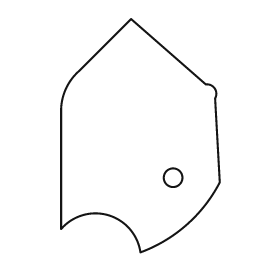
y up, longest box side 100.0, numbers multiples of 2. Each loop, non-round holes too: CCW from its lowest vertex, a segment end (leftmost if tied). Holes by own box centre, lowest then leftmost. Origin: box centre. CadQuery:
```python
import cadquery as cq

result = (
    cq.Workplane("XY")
    .moveTo(0.0, -50.0)
    .threePointArc((20.0, -38.0), (34.0, -20.0))
    .lineTo(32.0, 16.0)
    .threePointArc((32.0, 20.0), (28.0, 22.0))
    .lineTo(-4.0, 50.0)
    .lineTo(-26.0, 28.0)
    .threePointArc((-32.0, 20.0), (-34.0, 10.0))
    .lineTo(-34.0, -40.0)
    .threePointArc((-14.0, -34.0), (0.0, -50.0))
    .close()
    .moveTo(14.0, -18.0)
    .circle(4.0)
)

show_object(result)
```